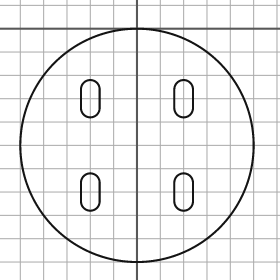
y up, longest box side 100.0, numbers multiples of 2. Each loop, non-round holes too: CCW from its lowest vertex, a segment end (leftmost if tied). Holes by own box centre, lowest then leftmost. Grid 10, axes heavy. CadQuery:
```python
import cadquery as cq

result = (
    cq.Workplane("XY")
    .moveTo(0.0, -50.0)
    .circle(50.0)
    .moveTo(-24.0, -74.0)
    .threePointArc((-20.0, -78.0), (-16.0, -74.0))
    .lineTo(-16.0, -66.0)
    .threePointArc((-20.0, -62.0), (-24.0, -66.0))
    .close()
    .moveTo(16.0, -74.0)
    .threePointArc((20.0, -78.0), (24.0, -74.0))
    .lineTo(24.0, -66.0)
    .threePointArc((20.0, -62.0), (16.0, -66.0))
    .close()
    .moveTo(-24.0, -34.0)
    .threePointArc((-20.0, -38.0), (-16.0, -34.0))
    .lineTo(-16.0, -26.0)
    .threePointArc((-20.0, -22.0), (-24.0, -26.0))
    .close()
    .moveTo(16.0, -34.0)
    .threePointArc((20.0, -38.0), (24.0, -34.0))
    .lineTo(24.0, -26.0)
    .threePointArc((20.0, -22.0), (16.0, -26.0))
    .close()
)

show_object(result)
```